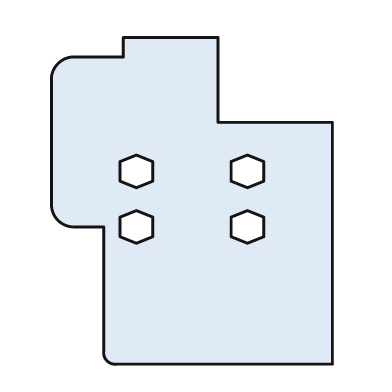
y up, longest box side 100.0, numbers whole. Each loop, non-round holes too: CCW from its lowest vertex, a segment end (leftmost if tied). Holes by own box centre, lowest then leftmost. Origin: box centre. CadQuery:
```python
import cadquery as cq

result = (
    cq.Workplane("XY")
    .moveTo(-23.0, -50.0)
    .lineTo(43.0, -50.0)
    .lineTo(43.0, 24.0)
    .lineTo(8.0, 24.0)
    .lineTo(8.0, 50.0)
    .lineTo(-21.0, 50.0)
    .lineTo(-21.0, 44.0)
    .lineTo(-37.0, 44.0)
    .threePointArc((-41.0, 42.0), (-43.0, 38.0))
    .lineTo(-43.0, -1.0)
    .threePointArc((-41.0, -6.0), (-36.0, -8.0))
    .lineTo(-27.0, -8.0)
    .lineTo(-27.0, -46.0)
    .threePointArc((-26.0, -49.0), (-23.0, -50.0))
    .close()
    .moveTo(-17.0, -13.0)
    .lineTo(-12.0, -11.0)
    .lineTo(-12.0, -5.0)
    .lineTo(-17.0, -3.0)
    .lineTo(-22.0, -5.0)
    .lineTo(-22.0, -11.0)
    .close()
    .moveTo(17.0, -13.0)
    .lineTo(22.0, -11.0)
    .lineTo(22.0, -5.0)
    .lineTo(17.0, -3.0)
    .lineTo(12.0, -5.0)
    .lineTo(12.0, -11.0)
    .close()
    .moveTo(-17.0, 4.0)
    .lineTo(-12.0, 6.0)
    .lineTo(-12.0, 12.0)
    .lineTo(-17.0, 14.0)
    .lineTo(-22.0, 12.0)
    .lineTo(-22.0, 6.0)
    .close()
    .moveTo(17.0, 4.0)
    .lineTo(22.0, 6.0)
    .lineTo(22.0, 12.0)
    .lineTo(17.0, 14.0)
    .lineTo(12.0, 12.0)
    .lineTo(12.0, 6.0)
    .close()
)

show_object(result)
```